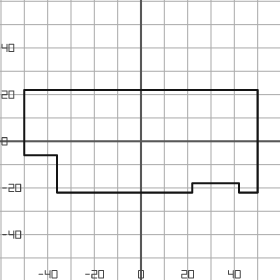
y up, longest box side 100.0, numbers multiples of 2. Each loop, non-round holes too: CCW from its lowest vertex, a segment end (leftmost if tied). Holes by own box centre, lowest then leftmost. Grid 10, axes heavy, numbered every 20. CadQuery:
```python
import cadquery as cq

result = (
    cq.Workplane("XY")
    .moveTo(-36.0, -22.0)
    .lineTo(22.0, -22.0)
    .lineTo(22.0, -18.0)
    .lineTo(42.0, -18.0)
    .lineTo(42.0, -22.0)
    .lineTo(50.0, -22.0)
    .lineTo(50.0, 22.0)
    .lineTo(-50.0, 22.0)
    .lineTo(-50.0, -6.0)
    .lineTo(-36.0, -6.0)
    .close()
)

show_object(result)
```